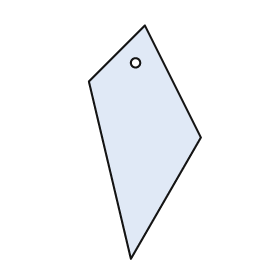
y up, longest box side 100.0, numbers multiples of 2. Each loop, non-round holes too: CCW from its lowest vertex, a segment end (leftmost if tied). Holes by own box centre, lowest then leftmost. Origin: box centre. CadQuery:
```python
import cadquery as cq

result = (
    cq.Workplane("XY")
    .moveTo(-6.0, -50.0)
    .lineTo(24.0, 2.0)
    .lineTo(0.0, 50.0)
    .lineTo(-24.0, 26.0)
    .close()
    .moveTo(-4.0, 34.0)
    .circle(2.0)
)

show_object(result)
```